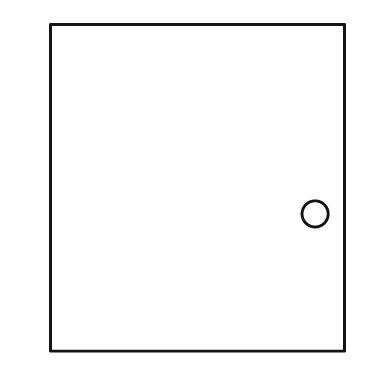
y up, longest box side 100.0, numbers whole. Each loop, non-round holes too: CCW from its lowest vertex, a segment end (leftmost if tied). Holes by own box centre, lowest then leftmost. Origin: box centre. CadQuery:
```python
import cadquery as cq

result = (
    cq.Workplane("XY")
    .moveTo(-45.0, -50.0)
    .lineTo(45.0, -50.0)
    .lineTo(45.0, 50.0)
    .lineTo(-45.0, 50.0)
    .close()
    .moveTo(36.0, -8.0)
    .circle(4.0)
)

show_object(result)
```